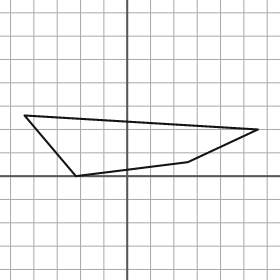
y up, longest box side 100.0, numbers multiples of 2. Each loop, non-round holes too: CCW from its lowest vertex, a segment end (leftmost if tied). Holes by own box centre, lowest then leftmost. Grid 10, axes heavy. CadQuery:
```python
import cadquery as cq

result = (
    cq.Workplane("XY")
    .moveTo(-22.0, 0.0)
    .lineTo(26.0, 6.0)
    .lineTo(56.0, 20.0)
    .lineTo(-44.0, 26.0)
    .close()
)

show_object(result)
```